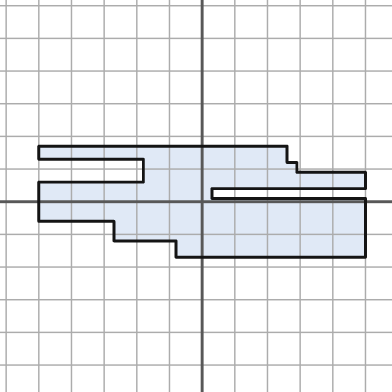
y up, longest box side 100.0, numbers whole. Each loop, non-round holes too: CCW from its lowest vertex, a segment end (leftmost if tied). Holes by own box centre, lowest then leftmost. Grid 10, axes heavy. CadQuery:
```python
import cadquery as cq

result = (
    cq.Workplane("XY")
    .moveTo(-8.0, -17.0)
    .lineTo(50.0, -17.0)
    .lineTo(50.0, 1.0)
    .lineTo(3.0, 1.0)
    .lineTo(3.0, 4.0)
    .lineTo(50.0, 4.0)
    .lineTo(50.0, 9.0)
    .lineTo(29.0, 9.0)
    .lineTo(29.0, 12.0)
    .lineTo(26.0, 12.0)
    .lineTo(26.0, 17.0)
    .lineTo(-50.0, 17.0)
    .lineTo(-50.0, 13.0)
    .lineTo(-18.0, 13.0)
    .lineTo(-18.0, 6.0)
    .lineTo(-50.0, 6.0)
    .lineTo(-50.0, -6.0)
    .lineTo(-27.0, -6.0)
    .lineTo(-27.0, -12.0)
    .lineTo(-8.0, -12.0)
    .close()
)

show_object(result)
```